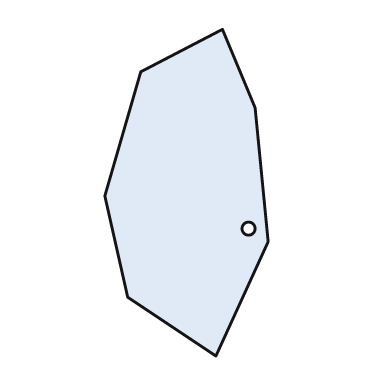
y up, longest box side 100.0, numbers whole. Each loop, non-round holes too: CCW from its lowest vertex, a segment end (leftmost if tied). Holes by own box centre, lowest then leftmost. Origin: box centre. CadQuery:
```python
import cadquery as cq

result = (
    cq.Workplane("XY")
    .moveTo(9.0, -50.0)
    .lineTo(25.0, -15.0)
    .lineTo(21.0, 26.0)
    .lineTo(11.0, 50.0)
    .lineTo(-14.0, 37.0)
    .lineTo(-25.0, -1.0)
    .lineTo(-18.0, -32.0)
    .close()
    .moveTo(19.0, -11.0)
    .circle(2.0)
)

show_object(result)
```